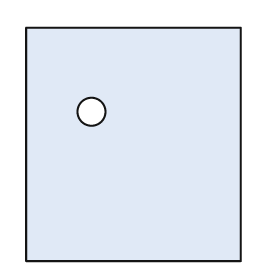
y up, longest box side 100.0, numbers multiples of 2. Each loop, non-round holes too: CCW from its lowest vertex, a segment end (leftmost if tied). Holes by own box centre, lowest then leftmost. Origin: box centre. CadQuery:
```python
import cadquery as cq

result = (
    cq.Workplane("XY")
    .moveTo(-46.0, -50.0)
    .lineTo(46.0, -50.0)
    .lineTo(46.0, 50.0)
    .lineTo(-46.0, 50.0)
    .close()
    .moveTo(-18.0, 14.0)
    .circle(6.0)
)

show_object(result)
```